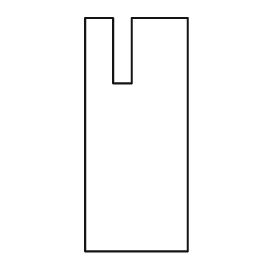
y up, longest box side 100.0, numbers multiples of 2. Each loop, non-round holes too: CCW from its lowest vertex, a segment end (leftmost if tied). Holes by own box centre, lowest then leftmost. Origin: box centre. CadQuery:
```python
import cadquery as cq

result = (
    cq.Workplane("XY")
    .moveTo(-22.0, -50.0)
    .lineTo(22.0, -50.0)
    .lineTo(22.0, 50.0)
    .lineTo(-2.0, 50.0)
    .lineTo(-2.0, 22.0)
    .lineTo(-10.0, 22.0)
    .lineTo(-10.0, 50.0)
    .lineTo(-22.0, 50.0)
    .close()
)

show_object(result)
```